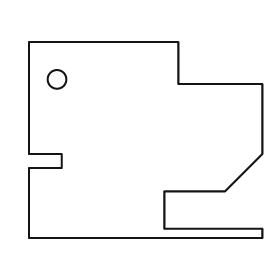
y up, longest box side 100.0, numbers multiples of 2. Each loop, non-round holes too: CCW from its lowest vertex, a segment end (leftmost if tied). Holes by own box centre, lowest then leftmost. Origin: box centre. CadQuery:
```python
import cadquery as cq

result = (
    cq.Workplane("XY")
    .moveTo(-50.0, -42.0)
    .lineTo(50.0, -42.0)
    .lineTo(50.0, -38.0)
    .lineTo(8.0, -38.0)
    .lineTo(8.0, -22.0)
    .lineTo(34.0, -22.0)
    .lineTo(50.0, -6.0)
    .lineTo(50.0, 24.0)
    .lineTo(14.0, 24.0)
    .lineTo(14.0, 42.0)
    .lineTo(-50.0, 42.0)
    .lineTo(-50.0, -6.0)
    .lineTo(-36.0, -6.0)
    .lineTo(-36.0, -12.0)
    .lineTo(-50.0, -12.0)
    .close()
    .moveTo(-38.0, 26.0)
    .circle(4.0)
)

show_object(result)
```